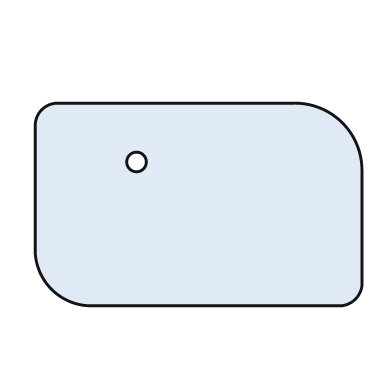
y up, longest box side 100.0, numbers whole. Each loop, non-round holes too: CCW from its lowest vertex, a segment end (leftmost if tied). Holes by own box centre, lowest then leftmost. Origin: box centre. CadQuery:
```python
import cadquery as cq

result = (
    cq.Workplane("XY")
    .moveTo(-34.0, -31.0)
    .lineTo(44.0, -31.0)
    .threePointArc((48.0, -29.0), (50.0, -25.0))
    .lineTo(50.0, 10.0)
    .threePointArc((44.0, 25.0), (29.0, 31.0))
    .lineTo(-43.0, 31.0)
    .threePointArc((-48.0, 29.0), (-50.0, 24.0))
    .lineTo(-50.0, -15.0)
    .threePointArc((-45.0, -26.0), (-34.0, -31.0))
    .close()
    .moveTo(-19.0, 13.0)
    .circle(3.0)
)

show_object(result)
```